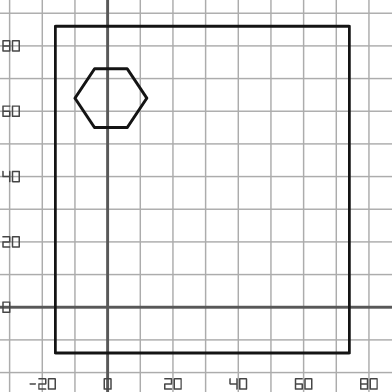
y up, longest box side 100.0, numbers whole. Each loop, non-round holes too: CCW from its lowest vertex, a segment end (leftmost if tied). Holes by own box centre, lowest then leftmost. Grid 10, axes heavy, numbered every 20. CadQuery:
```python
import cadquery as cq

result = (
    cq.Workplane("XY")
    .moveTo(-16.0, -14.0)
    .lineTo(74.0, -14.0)
    .lineTo(74.0, 86.0)
    .lineTo(-16.0, 86.0)
    .close()
    .moveTo(-4.0, 55.0)
    .lineTo(6.0, 55.0)
    .lineTo(12.0, 64.0)
    .lineTo(6.0, 73.0)
    .lineTo(-4.0, 73.0)
    .lineTo(-10.0, 64.0)
    .close()
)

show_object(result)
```